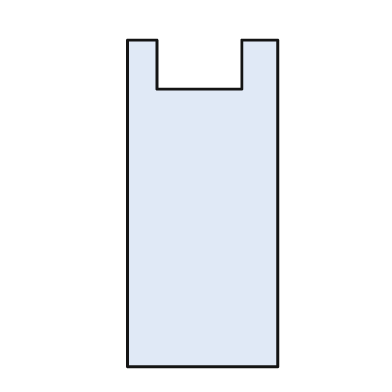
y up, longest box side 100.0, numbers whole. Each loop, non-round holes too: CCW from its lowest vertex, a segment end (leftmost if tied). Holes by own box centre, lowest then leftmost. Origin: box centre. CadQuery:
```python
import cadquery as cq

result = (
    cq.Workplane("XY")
    .moveTo(-23.0, -50.0)
    .lineTo(23.0, -50.0)
    .lineTo(23.0, 50.0)
    .lineTo(12.0, 50.0)
    .lineTo(12.0, 35.0)
    .lineTo(-14.0, 35.0)
    .lineTo(-14.0, 50.0)
    .lineTo(-23.0, 50.0)
    .close()
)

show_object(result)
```